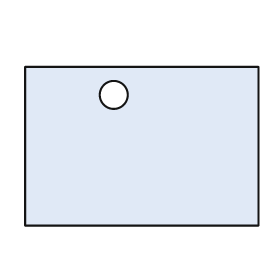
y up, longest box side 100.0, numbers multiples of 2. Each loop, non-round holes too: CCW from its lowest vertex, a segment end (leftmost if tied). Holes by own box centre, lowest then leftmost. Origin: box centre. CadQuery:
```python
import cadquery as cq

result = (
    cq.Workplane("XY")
    .moveTo(-50.0, -34.0)
    .lineTo(50.0, -34.0)
    .lineTo(50.0, 34.0)
    .lineTo(-50.0, 34.0)
    .close()
    .moveTo(-12.0, 22.0)
    .circle(6.0)
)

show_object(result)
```